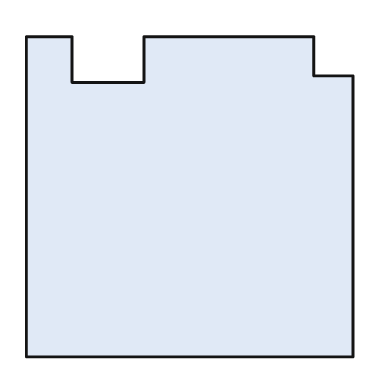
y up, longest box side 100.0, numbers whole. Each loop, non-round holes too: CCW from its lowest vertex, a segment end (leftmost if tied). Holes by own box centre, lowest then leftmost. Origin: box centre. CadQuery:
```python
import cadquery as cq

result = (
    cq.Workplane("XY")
    .moveTo(-50.0, -49.0)
    .lineTo(50.0, -49.0)
    .lineTo(50.0, 37.0)
    .lineTo(38.0, 37.0)
    .lineTo(38.0, 49.0)
    .lineTo(-14.0, 49.0)
    .lineTo(-14.0, 35.0)
    .lineTo(-36.0, 35.0)
    .lineTo(-36.0, 49.0)
    .lineTo(-50.0, 49.0)
    .close()
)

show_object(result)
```